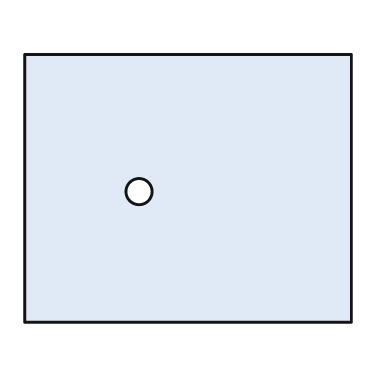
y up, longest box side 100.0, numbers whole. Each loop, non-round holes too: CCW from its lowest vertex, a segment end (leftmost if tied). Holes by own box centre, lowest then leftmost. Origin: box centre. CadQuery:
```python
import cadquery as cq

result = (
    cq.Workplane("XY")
    .moveTo(-50.0, -41.0)
    .lineTo(50.0, -41.0)
    .lineTo(50.0, 41.0)
    .lineTo(-50.0, 41.0)
    .close()
    .moveTo(-15.0, -1.0)
    .circle(4.0)
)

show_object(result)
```